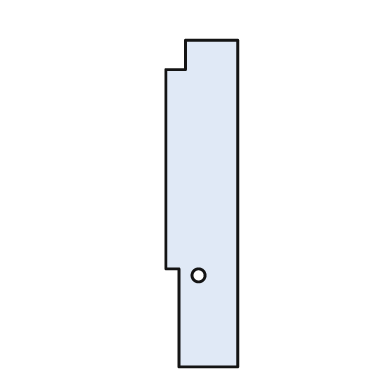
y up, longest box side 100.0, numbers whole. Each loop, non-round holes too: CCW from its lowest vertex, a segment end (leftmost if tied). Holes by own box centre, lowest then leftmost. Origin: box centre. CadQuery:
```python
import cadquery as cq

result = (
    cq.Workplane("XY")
    .moveTo(-7.0, -50.0)
    .lineTo(11.0, -50.0)
    .lineTo(11.0, 50.0)
    .lineTo(-5.0, 50.0)
    .lineTo(-5.0, 41.0)
    .lineTo(-11.0, 41.0)
    .lineTo(-11.0, -20.0)
    .lineTo(-7.0, -20.0)
    .close()
    .moveTo(-1.0, -22.0)
    .circle(2.0)
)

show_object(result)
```